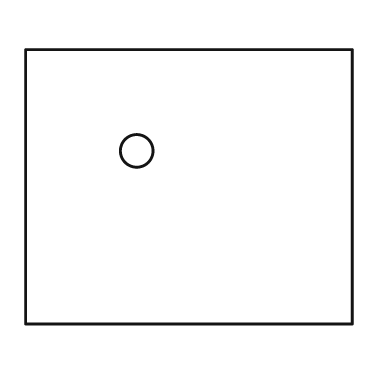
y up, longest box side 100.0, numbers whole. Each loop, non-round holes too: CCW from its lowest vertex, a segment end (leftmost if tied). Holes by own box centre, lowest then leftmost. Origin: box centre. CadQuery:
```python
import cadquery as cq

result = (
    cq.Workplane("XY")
    .moveTo(-50.0, -42.0)
    .lineTo(50.0, -42.0)
    .lineTo(50.0, 42.0)
    .lineTo(-50.0, 42.0)
    .close()
    .moveTo(-16.0, 11.0)
    .circle(5.0)
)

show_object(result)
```